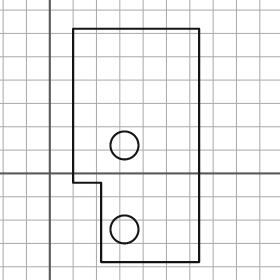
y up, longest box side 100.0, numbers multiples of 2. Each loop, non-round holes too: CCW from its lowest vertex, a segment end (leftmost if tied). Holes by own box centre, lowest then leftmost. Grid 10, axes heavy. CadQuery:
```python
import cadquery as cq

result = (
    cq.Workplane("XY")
    .moveTo(22.0, -38.0)
    .lineTo(64.0, -38.0)
    .lineTo(64.0, 62.0)
    .lineTo(10.0, 62.0)
    .lineTo(10.0, -4.0)
    .lineTo(22.0, -4.0)
    .close()
    .moveTo(32.0, -24.0)
    .circle(6.0)
    .moveTo(32.0, 12.0)
    .circle(6.0)
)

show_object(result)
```